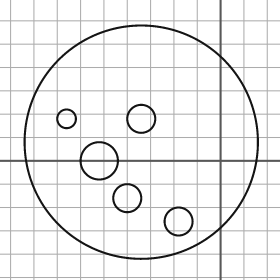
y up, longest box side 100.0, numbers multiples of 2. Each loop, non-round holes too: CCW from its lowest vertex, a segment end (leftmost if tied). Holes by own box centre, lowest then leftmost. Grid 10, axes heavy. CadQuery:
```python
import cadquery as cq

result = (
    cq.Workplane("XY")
    .moveTo(-34.0, 8.0)
    .circle(50.0)
    .moveTo(-18.0, -26.0)
    .circle(6.0)
    .moveTo(-40.0, -16.0)
    .circle(6.0)
    .moveTo(-52.0, 0.0)
    .circle(8.0)
    .moveTo(-66.0, 18.0)
    .circle(4.0)
    .moveTo(-34.0, 18.0)
    .circle(6.0)
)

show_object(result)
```